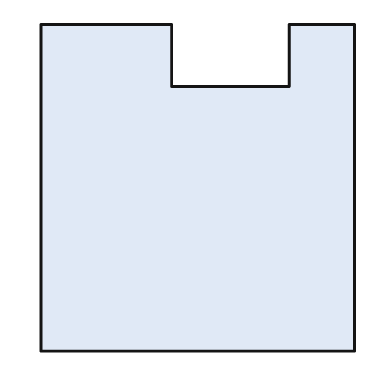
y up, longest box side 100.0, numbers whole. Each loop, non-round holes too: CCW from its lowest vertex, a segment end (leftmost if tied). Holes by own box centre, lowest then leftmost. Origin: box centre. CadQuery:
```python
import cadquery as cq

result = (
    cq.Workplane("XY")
    .moveTo(-48.0, -50.0)
    .lineTo(48.0, -50.0)
    .lineTo(48.0, 50.0)
    .lineTo(28.0, 50.0)
    .lineTo(28.0, 31.0)
    .lineTo(-8.0, 31.0)
    .lineTo(-8.0, 50.0)
    .lineTo(-48.0, 50.0)
    .close()
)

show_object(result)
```